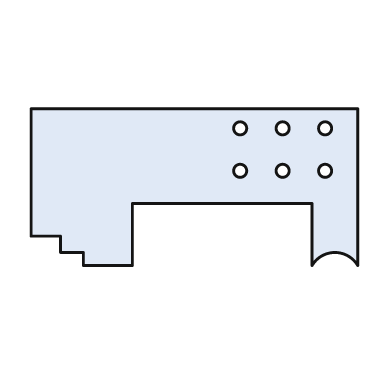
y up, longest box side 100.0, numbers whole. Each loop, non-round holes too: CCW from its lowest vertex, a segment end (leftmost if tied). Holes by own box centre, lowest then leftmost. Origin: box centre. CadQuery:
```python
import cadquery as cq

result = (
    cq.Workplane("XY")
    .moveTo(-34.0, -24.0)
    .lineTo(-19.0, -24.0)
    .lineTo(-19.0, -5.0)
    .lineTo(36.0, -5.0)
    .lineTo(36.0, -24.0)
    .threePointArc((43.0, -20.0), (50.0, -24.0))
    .lineTo(50.0, 24.0)
    .lineTo(-50.0, 24.0)
    .lineTo(-50.0, -15.0)
    .lineTo(-41.0, -15.0)
    .lineTo(-41.0, -20.0)
    .lineTo(-34.0, -20.0)
    .close()
    .moveTo(14.0, 5.0)
    .circle(2.0)
    .moveTo(27.0, 5.0)
    .circle(2.0)
    .moveTo(40.0, 5.0)
    .circle(2.0)
    .moveTo(14.0, 18.0)
    .circle(2.0)
    .moveTo(27.0, 18.0)
    .circle(2.0)
    .moveTo(40.0, 18.0)
    .circle(2.0)
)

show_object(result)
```